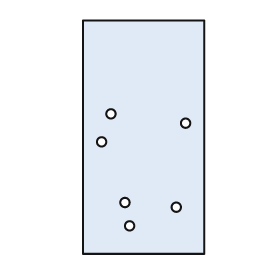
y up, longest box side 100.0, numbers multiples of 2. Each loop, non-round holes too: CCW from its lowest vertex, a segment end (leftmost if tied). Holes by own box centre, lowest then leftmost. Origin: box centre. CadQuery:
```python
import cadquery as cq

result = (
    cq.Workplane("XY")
    .moveTo(-26.0, -50.0)
    .lineTo(26.0, -50.0)
    .lineTo(26.0, 50.0)
    .lineTo(-26.0, 50.0)
    .close()
    .moveTo(-6.0, -38.0)
    .circle(2.0)
    .moveTo(14.0, -30.0)
    .circle(2.0)
    .moveTo(-8.0, -28.0)
    .circle(2.0)
    .moveTo(-18.0, -2.0)
    .circle(2.0)
    .moveTo(18.0, 6.0)
    .circle(2.0)
    .moveTo(-14.0, 10.0)
    .circle(2.0)
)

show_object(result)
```